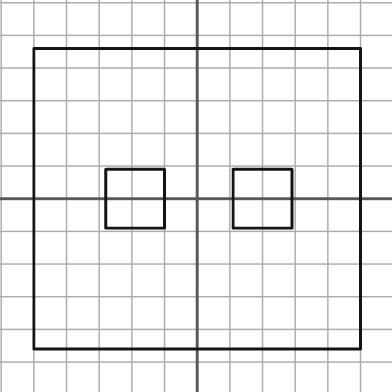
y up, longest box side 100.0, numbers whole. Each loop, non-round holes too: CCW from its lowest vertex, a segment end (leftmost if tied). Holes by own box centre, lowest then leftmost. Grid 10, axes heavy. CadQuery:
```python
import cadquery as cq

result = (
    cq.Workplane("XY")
    .moveTo(-50.0, -46.0)
    .lineTo(50.0, -46.0)
    .lineTo(50.0, 46.0)
    .lineTo(-50.0, 46.0)
    .close()
    .moveTo(-28.0, -9.0)
    .lineTo(-10.0, -9.0)
    .lineTo(-10.0, 9.0)
    .lineTo(-28.0, 9.0)
    .close()
    .moveTo(11.0, -9.0)
    .lineTo(29.0, -9.0)
    .lineTo(29.0, 9.0)
    .lineTo(11.0, 9.0)
    .close()
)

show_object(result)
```